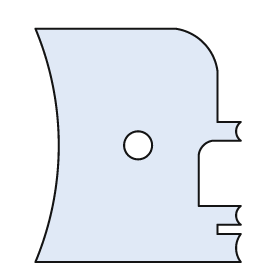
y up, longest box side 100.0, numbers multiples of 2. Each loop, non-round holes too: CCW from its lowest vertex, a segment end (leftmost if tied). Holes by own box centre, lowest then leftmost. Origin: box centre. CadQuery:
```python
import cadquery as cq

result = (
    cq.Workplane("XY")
    .moveTo(-44.0, -50.0)
    .lineTo(44.0, -50.0)
    .threePointArc((42.0, -44.0), (44.0, -38.0))
    .lineTo(34.0, -38.0)
    .lineTo(34.0, -34.0)
    .lineTo(44.0, -34.0)
    .threePointArc((42.0, -30.0), (44.0, -26.0))
    .lineTo(26.0, -26.0)
    .lineTo(26.0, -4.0)
    .threePointArc((28.0, 0.0), (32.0, 2.0))
    .lineTo(44.0, 2.0)
    .threePointArc((42.0, 6.0), (44.0, 10.0))
    .lineTo(34.0, 10.0)
    .lineTo(34.0, 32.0)
    .threePointArc((28.0, 44.0), (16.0, 50.0))
    .lineTo(-44.0, 50.0)
    .threePointArc((-34.0, 0.0), (-44.0, -50.0))
    .close()
    .moveTo(0.0, 0.0)
    .circle(6.0)
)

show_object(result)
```